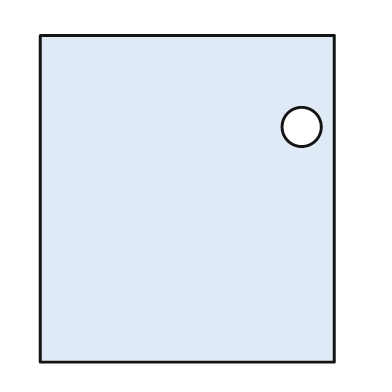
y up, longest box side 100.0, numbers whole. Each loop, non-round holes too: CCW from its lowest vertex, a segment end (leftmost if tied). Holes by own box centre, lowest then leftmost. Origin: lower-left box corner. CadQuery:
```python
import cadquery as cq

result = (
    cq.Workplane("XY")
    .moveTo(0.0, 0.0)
    .lineTo(90.0, 0.0)
    .lineTo(90.0, 100.0)
    .lineTo(0.0, 100.0)
    .close()
    .moveTo(80.0, 72.0)
    .circle(6.0)
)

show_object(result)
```